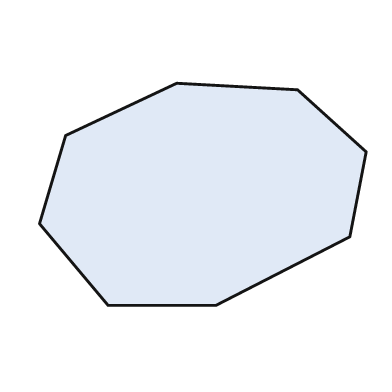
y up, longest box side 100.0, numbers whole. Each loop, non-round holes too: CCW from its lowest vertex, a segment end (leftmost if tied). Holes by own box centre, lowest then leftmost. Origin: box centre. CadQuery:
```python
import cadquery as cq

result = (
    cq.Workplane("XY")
    .moveTo(-29.0, -34.0)
    .lineTo(4.0, -34.0)
    .lineTo(45.0, -13.0)
    .lineTo(50.0, 13.0)
    .lineTo(29.0, 32.0)
    .lineTo(-8.0, 34.0)
    .lineTo(-42.0, 18.0)
    .lineTo(-50.0, -9.0)
    .close()
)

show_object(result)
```